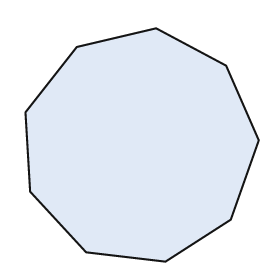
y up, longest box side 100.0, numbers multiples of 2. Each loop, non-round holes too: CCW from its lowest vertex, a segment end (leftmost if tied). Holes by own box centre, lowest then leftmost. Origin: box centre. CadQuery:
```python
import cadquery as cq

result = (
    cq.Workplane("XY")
    .moveTo(10.0, -50.0)
    .lineTo(38.0, -32.0)
    .lineTo(50.0, 2.0)
    .lineTo(36.0, 34.0)
    .lineTo(6.0, 50.0)
    .lineTo(-28.0, 42.0)
    .lineTo(-50.0, 14.0)
    .lineTo(-48.0, -20.0)
    .lineTo(-24.0, -46.0)
    .close()
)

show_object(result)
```